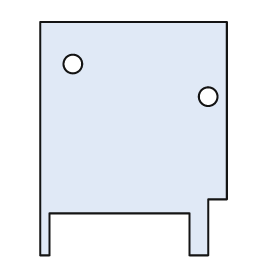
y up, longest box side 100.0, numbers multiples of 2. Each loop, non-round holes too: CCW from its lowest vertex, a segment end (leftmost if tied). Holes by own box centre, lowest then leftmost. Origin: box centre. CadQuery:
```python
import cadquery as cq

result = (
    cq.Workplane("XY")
    .moveTo(-40.0, -50.0)
    .lineTo(-36.0, -50.0)
    .lineTo(-36.0, -32.0)
    .lineTo(24.0, -32.0)
    .lineTo(24.0, -50.0)
    .lineTo(32.0, -50.0)
    .lineTo(32.0, -26.0)
    .lineTo(40.0, -26.0)
    .lineTo(40.0, 50.0)
    .lineTo(-40.0, 50.0)
    .close()
    .moveTo(32.0, 18.0)
    .circle(4.0)
    .moveTo(-26.0, 32.0)
    .circle(4.0)
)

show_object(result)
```